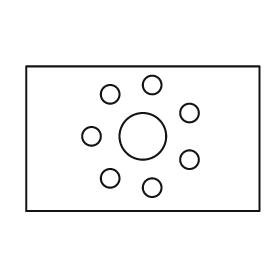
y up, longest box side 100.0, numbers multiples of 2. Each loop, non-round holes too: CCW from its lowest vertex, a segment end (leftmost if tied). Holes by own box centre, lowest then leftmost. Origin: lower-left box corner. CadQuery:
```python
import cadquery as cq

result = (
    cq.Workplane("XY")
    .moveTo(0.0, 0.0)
    .lineTo(100.0, 0.0)
    .lineTo(100.0, 62.0)
    .lineTo(0.0, 62.0)
    .close()
    .moveTo(54.0, 10.0)
    .circle(4.0)
    .moveTo(36.0, 14.0)
    .circle(4.0)
    .moveTo(70.0, 22.0)
    .circle(4.0)
    .moveTo(28.0, 32.0)
    .circle(4.0)
    .moveTo(50.0, 32.0)
    .circle(10.0)
    .moveTo(70.0, 42.0)
    .circle(4.0)
    .moveTo(36.0, 50.0)
    .circle(4.0)
    .moveTo(54.0, 54.0)
    .circle(4.0)
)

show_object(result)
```